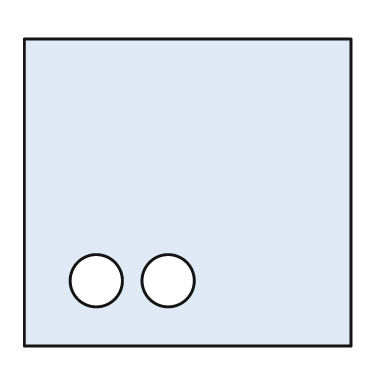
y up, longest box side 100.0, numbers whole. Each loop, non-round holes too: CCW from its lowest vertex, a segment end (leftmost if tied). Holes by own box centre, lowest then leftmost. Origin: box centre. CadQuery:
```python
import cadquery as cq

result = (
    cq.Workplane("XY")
    .moveTo(-50.0, -47.0)
    .lineTo(50.0, -47.0)
    .lineTo(50.0, 47.0)
    .lineTo(-50.0, 47.0)
    .close()
    .moveTo(-28.0, -27.0)
    .circle(8.0)
    .moveTo(-6.0, -27.0)
    .circle(8.0)
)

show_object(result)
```